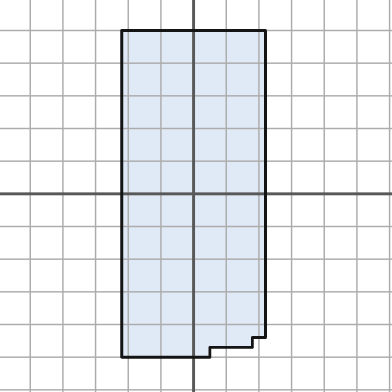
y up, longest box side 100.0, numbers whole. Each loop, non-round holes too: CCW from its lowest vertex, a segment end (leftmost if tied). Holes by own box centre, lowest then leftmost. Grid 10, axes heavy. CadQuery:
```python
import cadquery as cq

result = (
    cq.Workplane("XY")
    .moveTo(-22.0, -50.0)
    .lineTo(5.0, -50.0)
    .lineTo(5.0, -47.0)
    .lineTo(18.0, -47.0)
    .lineTo(18.0, -44.0)
    .lineTo(22.0, -44.0)
    .lineTo(22.0, 50.0)
    .lineTo(-22.0, 50.0)
    .close()
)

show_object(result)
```